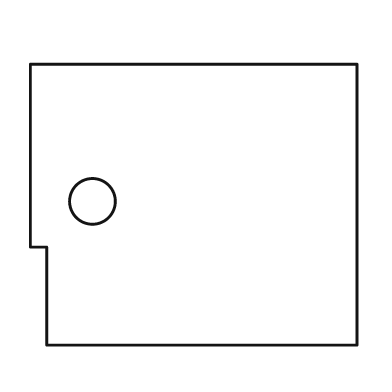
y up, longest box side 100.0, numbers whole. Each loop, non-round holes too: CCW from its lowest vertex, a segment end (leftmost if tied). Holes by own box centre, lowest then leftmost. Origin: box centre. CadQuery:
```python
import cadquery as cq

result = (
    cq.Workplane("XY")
    .moveTo(-45.0, -43.0)
    .lineTo(50.0, -43.0)
    .lineTo(50.0, 43.0)
    .lineTo(-50.0, 43.0)
    .lineTo(-50.0, -13.0)
    .lineTo(-45.0, -13.0)
    .close()
    .moveTo(-31.0, 1.0)
    .circle(7.0)
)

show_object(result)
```